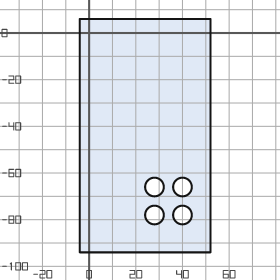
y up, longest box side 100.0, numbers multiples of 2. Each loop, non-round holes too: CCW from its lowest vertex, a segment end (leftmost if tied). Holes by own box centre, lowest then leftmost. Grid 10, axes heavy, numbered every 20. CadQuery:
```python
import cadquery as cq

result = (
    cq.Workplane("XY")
    .moveTo(-4.0, -94.0)
    .lineTo(52.0, -94.0)
    .lineTo(52.0, 6.0)
    .lineTo(-4.0, 6.0)
    .close()
    .moveTo(28.0, -78.0)
    .circle(4.0)
    .moveTo(40.0, -78.0)
    .circle(4.0)
    .moveTo(28.0, -66.0)
    .circle(4.0)
    .moveTo(40.0, -66.0)
    .circle(4.0)
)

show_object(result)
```